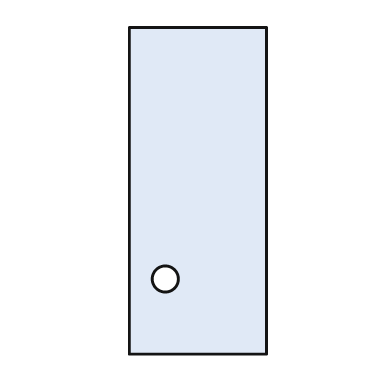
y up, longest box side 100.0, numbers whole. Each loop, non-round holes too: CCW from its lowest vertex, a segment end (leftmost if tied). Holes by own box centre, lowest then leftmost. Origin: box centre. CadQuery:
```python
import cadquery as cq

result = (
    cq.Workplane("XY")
    .moveTo(-21.0, -50.0)
    .lineTo(21.0, -50.0)
    .lineTo(21.0, 50.0)
    .lineTo(-21.0, 50.0)
    .close()
    .moveTo(-10.0, -27.0)
    .circle(4.0)
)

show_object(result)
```